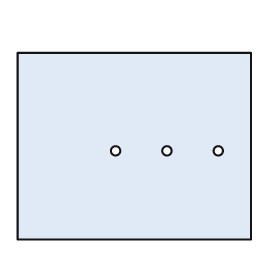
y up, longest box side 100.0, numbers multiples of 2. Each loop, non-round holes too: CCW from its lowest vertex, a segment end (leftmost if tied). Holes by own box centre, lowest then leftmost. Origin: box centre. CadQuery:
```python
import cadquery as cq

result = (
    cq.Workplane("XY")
    .moveTo(-50.0, -40.0)
    .lineTo(50.0, -40.0)
    .lineTo(50.0, 40.0)
    .lineTo(-50.0, 40.0)
    .close()
    .moveTo(-8.0, -2.0)
    .circle(2.0)
    .moveTo(14.0, -2.0)
    .circle(2.0)
    .moveTo(36.0, -2.0)
    .circle(2.0)
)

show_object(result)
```